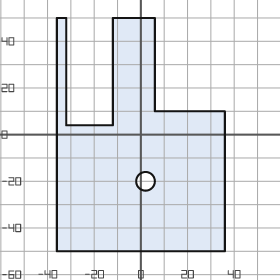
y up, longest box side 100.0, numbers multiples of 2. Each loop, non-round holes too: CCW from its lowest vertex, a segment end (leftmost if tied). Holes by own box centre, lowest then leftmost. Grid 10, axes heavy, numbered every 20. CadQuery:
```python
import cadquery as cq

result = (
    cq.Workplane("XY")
    .moveTo(-36.0, -50.0)
    .lineTo(36.0, -50.0)
    .lineTo(36.0, 10.0)
    .lineTo(6.0, 10.0)
    .lineTo(6.0, 50.0)
    .lineTo(-12.0, 50.0)
    .lineTo(-12.0, 4.0)
    .lineTo(-32.0, 4.0)
    .lineTo(-32.0, 50.0)
    .lineTo(-36.0, 50.0)
    .close()
    .moveTo(2.0, -20.0)
    .circle(4.0)
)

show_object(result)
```